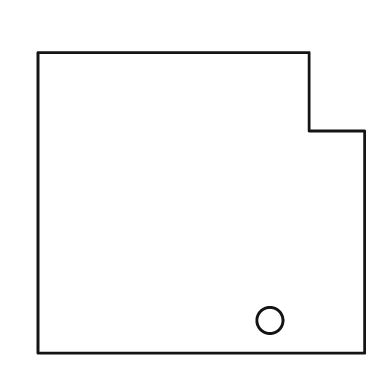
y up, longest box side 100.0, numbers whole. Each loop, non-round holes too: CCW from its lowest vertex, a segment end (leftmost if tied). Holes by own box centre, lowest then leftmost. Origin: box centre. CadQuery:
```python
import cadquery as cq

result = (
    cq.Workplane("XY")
    .moveTo(-50.0, -46.0)
    .lineTo(50.0, -46.0)
    .lineTo(50.0, 22.0)
    .lineTo(33.0, 22.0)
    .lineTo(33.0, 46.0)
    .lineTo(-50.0, 46.0)
    .close()
    .moveTo(21.0, -36.0)
    .circle(4.0)
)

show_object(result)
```